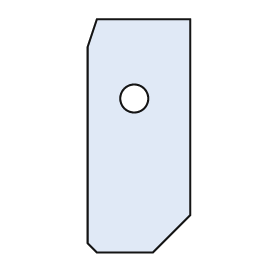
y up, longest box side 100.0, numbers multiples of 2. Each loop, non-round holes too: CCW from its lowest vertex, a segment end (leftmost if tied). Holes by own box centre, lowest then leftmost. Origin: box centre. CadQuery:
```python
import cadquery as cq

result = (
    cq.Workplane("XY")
    .moveTo(-18.0, -50.0)
    .lineTo(6.0, -50.0)
    .lineTo(22.0, -34.0)
    .lineTo(22.0, 50.0)
    .lineTo(-18.0, 50.0)
    .lineTo(-22.0, 38.0)
    .lineTo(-22.0, -46.0)
    .close()
    .moveTo(-2.0, 16.0)
    .circle(6.0)
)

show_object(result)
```